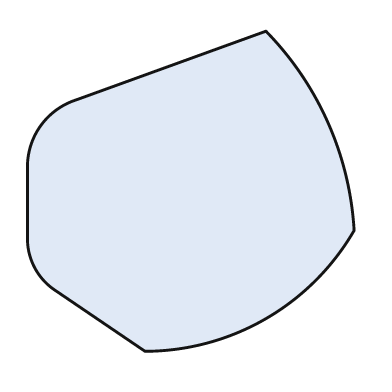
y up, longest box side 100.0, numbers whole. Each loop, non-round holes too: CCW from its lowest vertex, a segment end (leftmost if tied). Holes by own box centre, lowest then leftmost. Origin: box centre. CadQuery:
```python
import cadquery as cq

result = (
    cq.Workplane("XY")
    .moveTo(-14.0, -49.0)
    .threePointArc((23.0, -39.0), (50.0, -12.0))
    .threePointArc((42.0, 21.0), (23.0, 49.0))
    .lineTo(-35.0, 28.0)
    .threePointArc((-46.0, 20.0), (-50.0, 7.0))
    .lineTo(-50.0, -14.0)
    .threePointArc((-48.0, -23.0), (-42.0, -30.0))
    .close()
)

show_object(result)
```